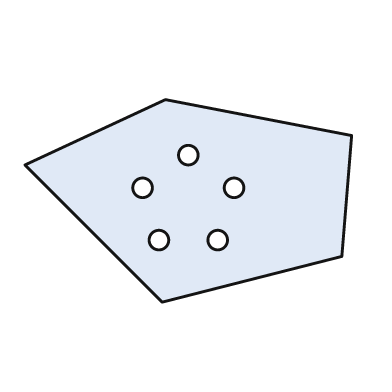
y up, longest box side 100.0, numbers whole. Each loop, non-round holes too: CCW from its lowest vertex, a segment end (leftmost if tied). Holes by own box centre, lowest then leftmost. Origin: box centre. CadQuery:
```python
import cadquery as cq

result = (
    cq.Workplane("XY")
    .moveTo(-8.0, -31.0)
    .lineTo(47.0, -17.0)
    .lineTo(50.0, 20.0)
    .lineTo(-7.0, 31.0)
    .lineTo(-50.0, 11.0)
    .close()
    .moveTo(-9.0, -12.0)
    .circle(3.0)
    .moveTo(9.0, -12.0)
    .circle(3.0)
    .moveTo(-14.0, 4.0)
    .circle(3.0)
    .moveTo(14.0, 4.0)
    .circle(3.0)
    .moveTo(0.0, 14.0)
    .circle(3.0)
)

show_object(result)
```